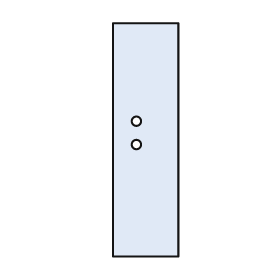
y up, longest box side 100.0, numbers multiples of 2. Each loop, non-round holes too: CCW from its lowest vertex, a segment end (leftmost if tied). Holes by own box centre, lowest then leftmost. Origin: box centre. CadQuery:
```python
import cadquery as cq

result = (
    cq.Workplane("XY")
    .moveTo(-14.0, -50.0)
    .lineTo(14.0, -50.0)
    .lineTo(14.0, 50.0)
    .lineTo(-14.0, 50.0)
    .close()
    .moveTo(-4.0, -2.0)
    .circle(2.0)
    .moveTo(-4.0, 8.0)
    .circle(2.0)
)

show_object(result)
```